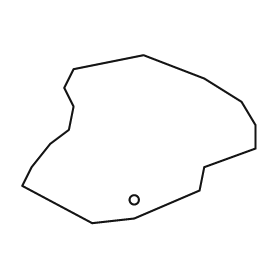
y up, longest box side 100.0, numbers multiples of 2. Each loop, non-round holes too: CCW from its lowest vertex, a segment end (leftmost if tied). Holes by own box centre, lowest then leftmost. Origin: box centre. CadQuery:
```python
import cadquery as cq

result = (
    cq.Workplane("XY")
    .moveTo(-20.0, -36.0)
    .lineTo(-2.0, -34.0)
    .lineTo(26.0, -22.0)
    .lineTo(28.0, -12.0)
    .lineTo(50.0, -4.0)
    .lineTo(50.0, 6.0)
    .lineTo(44.0, 16.0)
    .lineTo(28.0, 26.0)
    .lineTo(2.0, 36.0)
    .lineTo(-28.0, 30.0)
    .lineTo(-32.0, 22.0)
    .lineTo(-28.0, 14.0)
    .lineTo(-30.0, 4.0)
    .lineTo(-38.0, -2.0)
    .lineTo(-46.0, -12.0)
    .lineTo(-50.0, -20.0)
    .close()
    .moveTo(-2.0, -26.0)
    .circle(2.0)
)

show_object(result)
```